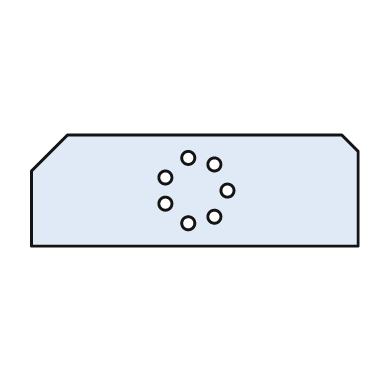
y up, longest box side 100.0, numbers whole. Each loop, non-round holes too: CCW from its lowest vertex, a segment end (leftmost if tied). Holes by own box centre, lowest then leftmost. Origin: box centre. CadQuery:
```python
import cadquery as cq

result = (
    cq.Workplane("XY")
    .moveTo(-50.0, -17.0)
    .lineTo(50.0, -17.0)
    .lineTo(50.0, 12.0)
    .lineTo(45.0, 17.0)
    .lineTo(-39.0, 17.0)
    .lineTo(-50.0, 6.0)
    .close()
    .moveTo(-2.0, -10.0)
    .circle(2.0)
    .moveTo(6.0, -8.0)
    .circle(2.0)
    .moveTo(-9.0, -4.0)
    .circle(2.0)
    .moveTo(10.0, 0.0)
    .circle(2.0)
    .moveTo(-9.0, 4.0)
    .circle(2.0)
    .moveTo(6.0, 8.0)
    .circle(2.0)
    .moveTo(-2.0, 10.0)
    .circle(2.0)
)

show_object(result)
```